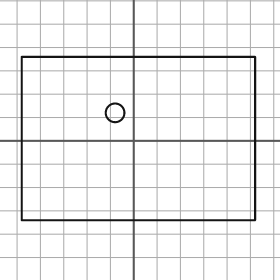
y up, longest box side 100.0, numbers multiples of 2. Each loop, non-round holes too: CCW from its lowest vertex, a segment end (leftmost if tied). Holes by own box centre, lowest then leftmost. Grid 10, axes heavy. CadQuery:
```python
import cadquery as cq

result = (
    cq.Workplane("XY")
    .moveTo(-48.0, -34.0)
    .lineTo(52.0, -34.0)
    .lineTo(52.0, 36.0)
    .lineTo(-48.0, 36.0)
    .close()
    .moveTo(-8.0, 12.0)
    .circle(4.0)
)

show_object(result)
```